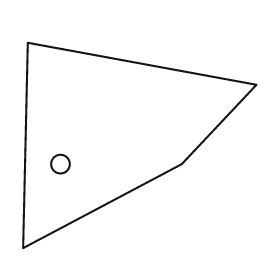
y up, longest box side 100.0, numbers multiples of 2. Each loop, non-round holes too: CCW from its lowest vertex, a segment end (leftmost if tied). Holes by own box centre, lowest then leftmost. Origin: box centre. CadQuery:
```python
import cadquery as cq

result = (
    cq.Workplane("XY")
    .moveTo(-50.0, -44.0)
    .lineTo(18.0, -8.0)
    .lineTo(50.0, 26.0)
    .lineTo(-48.0, 44.0)
    .close()
    .moveTo(-34.0, -8.0)
    .circle(4.0)
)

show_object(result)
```